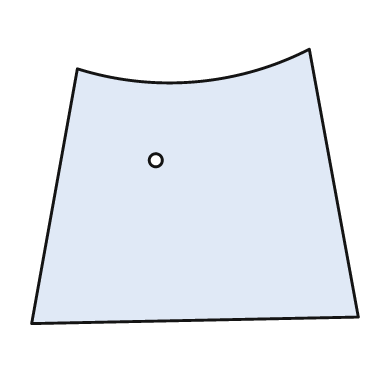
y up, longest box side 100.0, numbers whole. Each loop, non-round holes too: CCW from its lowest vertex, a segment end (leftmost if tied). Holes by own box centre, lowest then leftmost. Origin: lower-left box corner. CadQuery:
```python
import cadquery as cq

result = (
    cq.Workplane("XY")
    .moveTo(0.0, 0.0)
    .lineTo(100.0, 2.0)
    .lineTo(85.0, 84.0)
    .threePointArc((50.0, 74.0), (14.0, 78.0))
    .close()
    .moveTo(38.0, 50.0)
    .circle(2.0)
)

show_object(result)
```